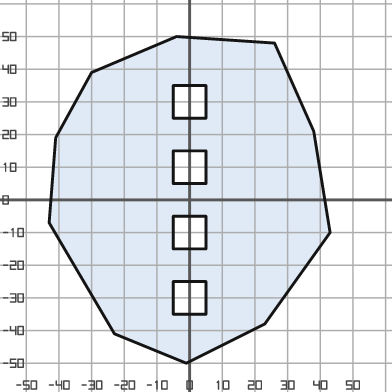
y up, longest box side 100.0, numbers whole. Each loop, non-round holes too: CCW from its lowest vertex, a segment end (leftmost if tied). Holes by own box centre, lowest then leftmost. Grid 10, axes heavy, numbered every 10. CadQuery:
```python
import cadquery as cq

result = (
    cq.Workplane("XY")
    .moveTo(-1.0, -50.0)
    .lineTo(23.0, -38.0)
    .lineTo(43.0, -10.0)
    .lineTo(38.0, 21.0)
    .lineTo(26.0, 48.0)
    .lineTo(-4.0, 50.0)
    .lineTo(-30.0, 39.0)
    .lineTo(-41.0, 19.0)
    .lineTo(-43.0, -7.0)
    .lineTo(-23.0, -41.0)
    .close()
    .moveTo(-5.0, -35.0)
    .lineTo(5.0, -35.0)
    .lineTo(5.0, -25.0)
    .lineTo(-5.0, -25.0)
    .close()
    .moveTo(-5.0, -15.0)
    .lineTo(5.0, -15.0)
    .lineTo(5.0, -5.0)
    .lineTo(-5.0, -5.0)
    .close()
    .moveTo(-5.0, 5.0)
    .lineTo(5.0, 5.0)
    .lineTo(5.0, 15.0)
    .lineTo(-5.0, 15.0)
    .close()
    .moveTo(-5.0, 25.0)
    .lineTo(5.0, 25.0)
    .lineTo(5.0, 35.0)
    .lineTo(-5.0, 35.0)
    .close()
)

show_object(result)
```